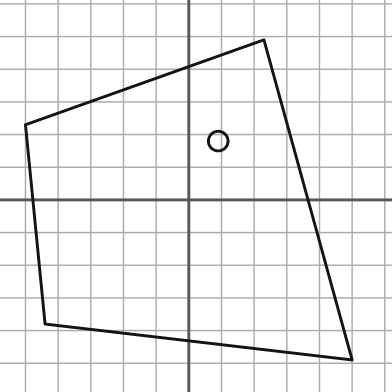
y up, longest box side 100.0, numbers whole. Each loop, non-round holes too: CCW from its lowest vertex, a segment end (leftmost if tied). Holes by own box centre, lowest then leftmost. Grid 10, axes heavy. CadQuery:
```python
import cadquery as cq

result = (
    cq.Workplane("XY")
    .moveTo(50.0, -49.0)
    .lineTo(23.0, 49.0)
    .lineTo(-50.0, 23.0)
    .lineTo(-44.0, -38.0)
    .close()
    .moveTo(9.0, 18.0)
    .circle(3.0)
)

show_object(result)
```